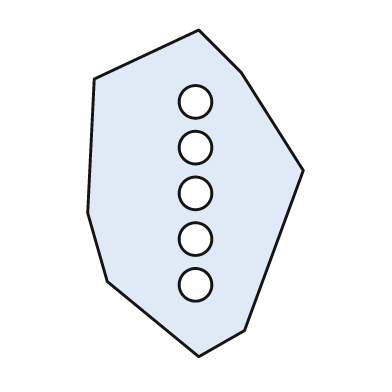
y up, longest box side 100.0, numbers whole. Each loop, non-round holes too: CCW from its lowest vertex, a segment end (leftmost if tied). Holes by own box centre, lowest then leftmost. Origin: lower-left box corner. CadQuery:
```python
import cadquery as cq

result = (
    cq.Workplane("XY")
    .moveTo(34.0, 0.0)
    .lineTo(48.0, 8.0)
    .lineTo(66.0, 57.0)
    .lineTo(47.0, 87.0)
    .lineTo(34.0, 100.0)
    .lineTo(2.0, 85.0)
    .lineTo(0.0, 44.0)
    .lineTo(6.0, 23.0)
    .close()
    .moveTo(33.0, 22.0)
    .circle(5.0)
    .moveTo(33.0, 36.0)
    .circle(5.0)
    .moveTo(33.0, 50.0)
    .circle(5.0)
    .moveTo(33.0, 64.0)
    .circle(5.0)
    .moveTo(33.0, 78.0)
    .circle(5.0)
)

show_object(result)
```